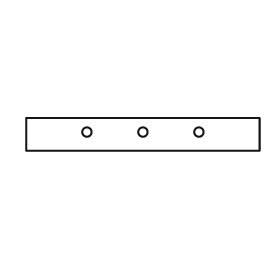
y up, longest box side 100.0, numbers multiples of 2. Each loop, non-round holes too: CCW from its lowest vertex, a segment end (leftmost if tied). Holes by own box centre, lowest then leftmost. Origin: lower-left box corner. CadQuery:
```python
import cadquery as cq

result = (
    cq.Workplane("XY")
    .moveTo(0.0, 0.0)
    .lineTo(100.0, 0.0)
    .lineTo(100.0, 14.0)
    .lineTo(0.0, 14.0)
    .close()
    .moveTo(26.0, 8.0)
    .circle(2.0)
    .moveTo(50.0, 8.0)
    .circle(2.0)
    .moveTo(74.0, 8.0)
    .circle(2.0)
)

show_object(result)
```